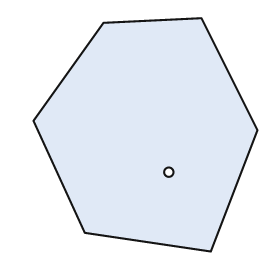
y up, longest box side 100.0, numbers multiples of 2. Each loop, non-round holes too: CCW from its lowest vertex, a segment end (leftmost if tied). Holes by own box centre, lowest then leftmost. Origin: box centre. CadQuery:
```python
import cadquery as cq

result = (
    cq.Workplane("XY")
    .moveTo(28.0, -50.0)
    .lineTo(48.0, 2.0)
    .lineTo(24.0, 50.0)
    .lineTo(-18.0, 48.0)
    .lineTo(-48.0, 6.0)
    .lineTo(-26.0, -42.0)
    .close()
    .moveTo(10.0, -16.0)
    .circle(2.0)
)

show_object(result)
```